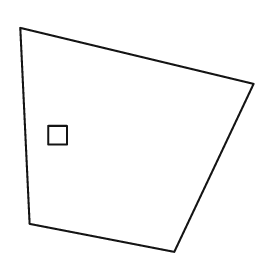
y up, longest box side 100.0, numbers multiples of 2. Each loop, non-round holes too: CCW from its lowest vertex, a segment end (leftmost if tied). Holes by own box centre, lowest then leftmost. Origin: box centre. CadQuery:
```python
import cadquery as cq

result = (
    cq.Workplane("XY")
    .moveTo(16.0, -48.0)
    .lineTo(50.0, 24.0)
    .lineTo(-50.0, 48.0)
    .lineTo(-46.0, -36.0)
    .close()
    .moveTo(-38.0, -2.0)
    .lineTo(-30.0, -2.0)
    .lineTo(-30.0, 6.0)
    .lineTo(-38.0, 6.0)
    .close()
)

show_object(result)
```